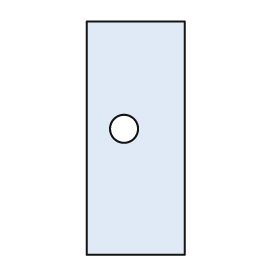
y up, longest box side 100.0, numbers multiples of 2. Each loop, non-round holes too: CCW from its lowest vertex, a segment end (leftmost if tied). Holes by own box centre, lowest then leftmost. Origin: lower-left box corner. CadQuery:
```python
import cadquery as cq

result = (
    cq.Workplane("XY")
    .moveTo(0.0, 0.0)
    .lineTo(42.0, 0.0)
    .lineTo(42.0, 100.0)
    .lineTo(0.0, 100.0)
    .close()
    .moveTo(16.0, 54.0)
    .circle(6.0)
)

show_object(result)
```